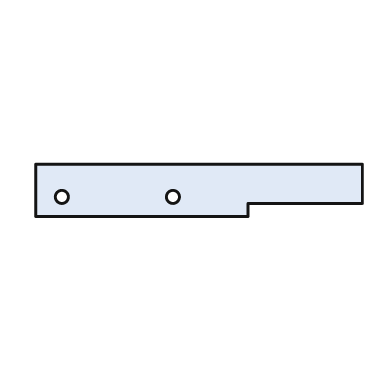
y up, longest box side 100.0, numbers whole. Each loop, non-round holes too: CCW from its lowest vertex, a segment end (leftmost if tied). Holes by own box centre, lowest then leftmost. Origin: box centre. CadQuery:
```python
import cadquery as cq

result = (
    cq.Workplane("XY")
    .moveTo(-50.0, -8.0)
    .lineTo(15.0, -8.0)
    .lineTo(15.0, -4.0)
    .lineTo(50.0, -4.0)
    .lineTo(50.0, 8.0)
    .lineTo(-50.0, 8.0)
    .close()
    .moveTo(-42.0, -2.0)
    .circle(2.0)
    .moveTo(-8.0, -2.0)
    .circle(2.0)
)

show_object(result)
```